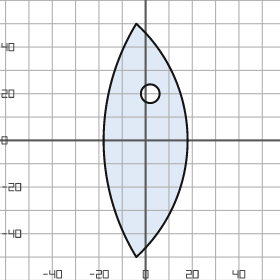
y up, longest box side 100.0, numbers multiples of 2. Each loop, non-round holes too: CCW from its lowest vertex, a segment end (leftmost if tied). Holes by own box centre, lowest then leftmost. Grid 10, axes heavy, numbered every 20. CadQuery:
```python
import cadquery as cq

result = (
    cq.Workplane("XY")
    .moveTo(-4.0, -50.0)
    .threePointArc((18.0, 0.0), (-4.0, 50.0))
    .threePointArc((-18.0, 0.0), (-4.0, -50.0))
    .close()
    .moveTo(2.0, 20.0)
    .circle(4.0)
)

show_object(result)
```